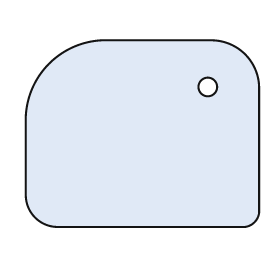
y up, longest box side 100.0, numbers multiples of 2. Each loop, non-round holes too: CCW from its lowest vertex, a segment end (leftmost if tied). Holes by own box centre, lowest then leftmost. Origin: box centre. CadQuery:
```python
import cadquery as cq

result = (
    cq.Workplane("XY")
    .moveTo(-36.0, -40.0)
    .lineTo(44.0, -40.0)
    .threePointArc((48.0, -38.0), (50.0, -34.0))
    .lineTo(50.0, 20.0)
    .threePointArc((44.0, 34.0), (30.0, 40.0))
    .lineTo(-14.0, 40.0)
    .threePointArc((-40.0, 30.0), (-50.0, 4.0))
    .lineTo(-50.0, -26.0)
    .threePointArc((-46.0, -36.0), (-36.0, -40.0))
    .close()
    .moveTo(28.0, 20.0)
    .circle(4.0)
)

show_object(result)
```